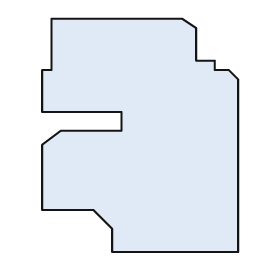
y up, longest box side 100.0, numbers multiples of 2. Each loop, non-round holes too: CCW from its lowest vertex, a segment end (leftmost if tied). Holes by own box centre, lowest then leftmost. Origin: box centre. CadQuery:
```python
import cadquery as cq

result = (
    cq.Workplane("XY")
    .moveTo(-12.0, -50.0)
    .lineTo(42.0, -50.0)
    .lineTo(42.0, 24.0)
    .lineTo(38.0, 28.0)
    .lineTo(32.0, 28.0)
    .lineTo(32.0, 32.0)
    .lineTo(24.0, 32.0)
    .lineTo(24.0, 46.0)
    .lineTo(18.0, 50.0)
    .lineTo(-38.0, 50.0)
    .lineTo(-38.0, 28.0)
    .lineTo(-42.0, 28.0)
    .lineTo(-42.0, 10.0)
    .lineTo(-8.0, 10.0)
    .lineTo(-8.0, 2.0)
    .lineTo(-34.0, 2.0)
    .lineTo(-42.0, -4.0)
    .lineTo(-42.0, -32.0)
    .lineTo(-20.0, -32.0)
    .lineTo(-12.0, -40.0)
    .close()
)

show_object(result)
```